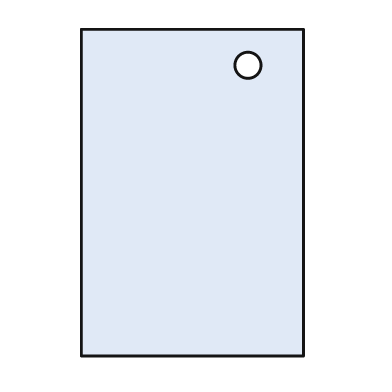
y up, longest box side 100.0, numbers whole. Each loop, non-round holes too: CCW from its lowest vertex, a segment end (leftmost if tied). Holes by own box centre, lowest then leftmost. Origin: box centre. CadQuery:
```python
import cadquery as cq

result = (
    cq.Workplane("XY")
    .moveTo(-34.0, -50.0)
    .lineTo(34.0, -50.0)
    .lineTo(34.0, 50.0)
    .lineTo(-34.0, 50.0)
    .close()
    .moveTo(17.0, 39.0)
    .circle(4.0)
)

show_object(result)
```